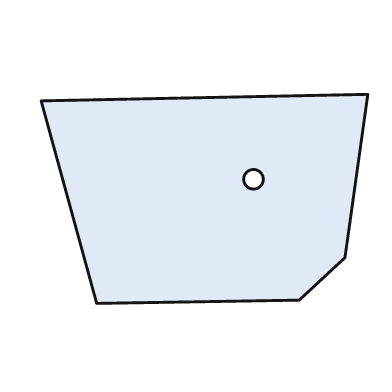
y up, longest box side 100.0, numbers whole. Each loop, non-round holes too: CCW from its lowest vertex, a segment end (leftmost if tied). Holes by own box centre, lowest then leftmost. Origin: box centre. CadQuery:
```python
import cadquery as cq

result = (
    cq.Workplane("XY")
    .moveTo(-33.0, -32.0)
    .lineTo(29.0, -31.0)
    .lineTo(43.0, -18.0)
    .lineTo(50.0, 32.0)
    .lineTo(-50.0, 30.0)
    .close()
    .moveTo(15.0, 6.0)
    .circle(3.0)
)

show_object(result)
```